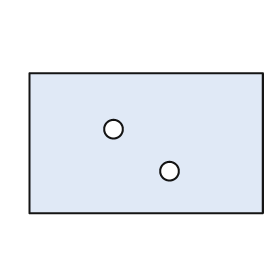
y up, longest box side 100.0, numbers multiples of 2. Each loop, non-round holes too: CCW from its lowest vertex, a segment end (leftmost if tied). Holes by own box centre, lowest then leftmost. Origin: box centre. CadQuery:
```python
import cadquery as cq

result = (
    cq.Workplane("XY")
    .moveTo(-50.0, -30.0)
    .lineTo(50.0, -30.0)
    .lineTo(50.0, 30.0)
    .lineTo(-50.0, 30.0)
    .close()
    .moveTo(10.0, -12.0)
    .circle(4.0)
    .moveTo(-14.0, 6.0)
    .circle(4.0)
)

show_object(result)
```